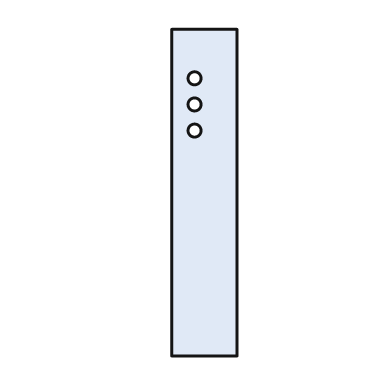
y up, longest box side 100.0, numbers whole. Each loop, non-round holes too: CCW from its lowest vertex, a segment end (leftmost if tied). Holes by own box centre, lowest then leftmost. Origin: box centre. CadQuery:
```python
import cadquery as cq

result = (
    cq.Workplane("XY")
    .moveTo(-10.0, -50.0)
    .lineTo(10.0, -50.0)
    .lineTo(10.0, 50.0)
    .lineTo(-10.0, 50.0)
    .close()
    .moveTo(-3.0, 19.0)
    .circle(2.0)
    .moveTo(-3.0, 27.0)
    .circle(2.0)
    .moveTo(-3.0, 35.0)
    .circle(2.0)
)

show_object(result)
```